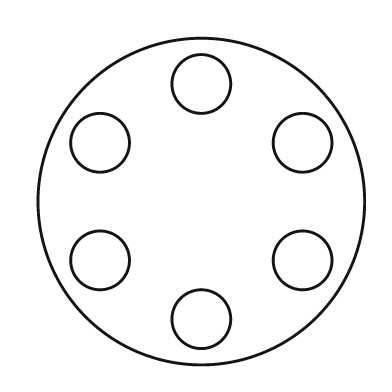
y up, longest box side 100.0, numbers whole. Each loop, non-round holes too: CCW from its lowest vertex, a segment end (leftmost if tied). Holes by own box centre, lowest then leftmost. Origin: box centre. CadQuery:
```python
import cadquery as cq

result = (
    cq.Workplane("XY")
    .moveTo(0.0, 0.0)
    .circle(50.0)
    .moveTo(0.0, -36.0)
    .circle(9.0)
    .moveTo(-31.0, -18.0)
    .circle(9.0)
    .moveTo(31.0, -18.0)
    .circle(9.0)
    .moveTo(-31.0, 18.0)
    .circle(9.0)
    .moveTo(31.0, 18.0)
    .circle(9.0)
    .moveTo(0.0, 36.0)
    .circle(9.0)
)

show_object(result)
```